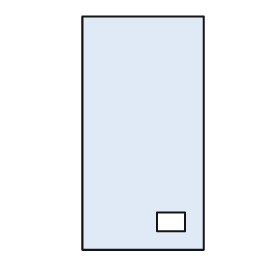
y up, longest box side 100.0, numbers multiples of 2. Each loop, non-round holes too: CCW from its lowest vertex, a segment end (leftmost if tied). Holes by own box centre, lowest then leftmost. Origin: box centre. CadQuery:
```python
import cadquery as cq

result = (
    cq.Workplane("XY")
    .moveTo(-26.0, -50.0)
    .lineTo(26.0, -50.0)
    .lineTo(26.0, 50.0)
    .lineTo(-26.0, 50.0)
    .close()
    .moveTo(6.0, -42.0)
    .lineTo(18.0, -42.0)
    .lineTo(18.0, -34.0)
    .lineTo(6.0, -34.0)
    .close()
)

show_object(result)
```